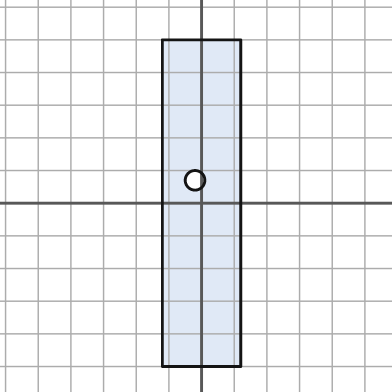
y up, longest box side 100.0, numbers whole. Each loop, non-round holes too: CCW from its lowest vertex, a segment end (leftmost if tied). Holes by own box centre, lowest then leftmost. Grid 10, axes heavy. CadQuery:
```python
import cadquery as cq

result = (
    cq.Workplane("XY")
    .moveTo(-12.0, -50.0)
    .lineTo(12.0, -50.0)
    .lineTo(12.0, 50.0)
    .lineTo(-12.0, 50.0)
    .close()
    .moveTo(-2.0, 7.0)
    .circle(3.0)
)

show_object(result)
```